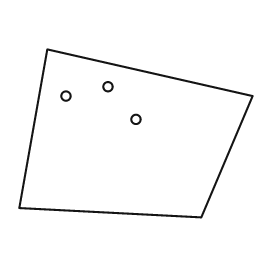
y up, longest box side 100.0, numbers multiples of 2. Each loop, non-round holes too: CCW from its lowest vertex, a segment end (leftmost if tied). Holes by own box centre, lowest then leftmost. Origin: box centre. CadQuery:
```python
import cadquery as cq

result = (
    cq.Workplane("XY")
    .moveTo(28.0, -36.0)
    .lineTo(50.0, 16.0)
    .lineTo(-38.0, 36.0)
    .lineTo(-50.0, -32.0)
    .close()
    .moveTo(0.0, 6.0)
    .circle(2.0)
    .moveTo(-30.0, 16.0)
    .circle(2.0)
    .moveTo(-12.0, 20.0)
    .circle(2.0)
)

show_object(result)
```